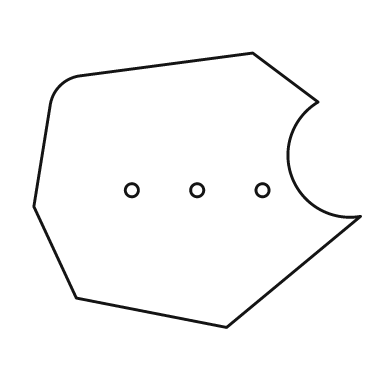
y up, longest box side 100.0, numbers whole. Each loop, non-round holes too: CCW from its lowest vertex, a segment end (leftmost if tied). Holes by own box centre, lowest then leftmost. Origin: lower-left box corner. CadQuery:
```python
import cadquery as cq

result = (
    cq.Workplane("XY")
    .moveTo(59.0, 0.0)
    .lineTo(100.0, 34.0)
    .threePointArc((79.0, 46.0), (87.0, 69.0))
    .lineTo(67.0, 84.0)
    .lineTo(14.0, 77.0)
    .threePointArc((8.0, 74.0), (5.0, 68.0))
    .lineTo(0.0, 37.0)
    .lineTo(13.0, 9.0)
    .close()
    .moveTo(30.0, 42.0)
    .circle(2.0)
    .moveTo(50.0, 42.0)
    .circle(2.0)
    .moveTo(70.0, 42.0)
    .circle(2.0)
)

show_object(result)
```